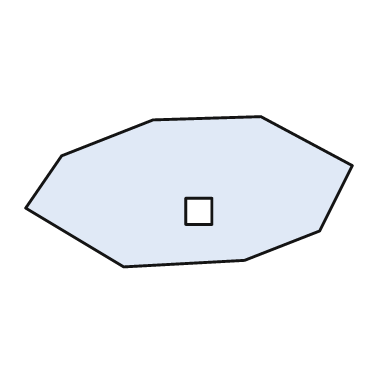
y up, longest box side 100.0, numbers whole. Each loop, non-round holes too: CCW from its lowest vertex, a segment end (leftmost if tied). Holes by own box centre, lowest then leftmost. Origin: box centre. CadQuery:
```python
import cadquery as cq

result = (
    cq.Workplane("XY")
    .moveTo(-20.0, -23.0)
    .lineTo(17.0, -21.0)
    .lineTo(40.0, -12.0)
    .lineTo(50.0, 8.0)
    .lineTo(22.0, 23.0)
    .lineTo(-11.0, 22.0)
    .lineTo(-39.0, 11.0)
    .lineTo(-50.0, -5.0)
    .close()
    .moveTo(-1.0, -10.0)
    .lineTo(7.0, -10.0)
    .lineTo(7.0, -2.0)
    .lineTo(-1.0, -2.0)
    .close()
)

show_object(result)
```